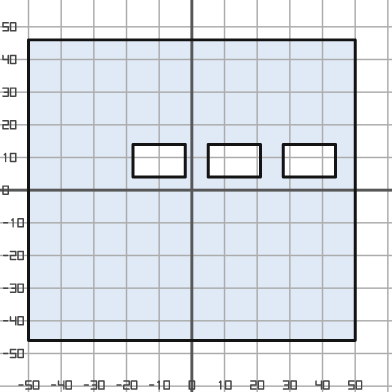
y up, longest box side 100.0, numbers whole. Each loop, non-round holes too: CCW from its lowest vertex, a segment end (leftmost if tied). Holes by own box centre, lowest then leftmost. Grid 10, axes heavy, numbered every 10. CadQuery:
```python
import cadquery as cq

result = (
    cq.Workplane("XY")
    .moveTo(-50.0, -46.0)
    .lineTo(50.0, -46.0)
    .lineTo(50.0, 46.0)
    .lineTo(-50.0, 46.0)
    .close()
    .moveTo(-18.0, 4.0)
    .lineTo(-2.0, 4.0)
    .lineTo(-2.0, 14.0)
    .lineTo(-18.0, 14.0)
    .close()
    .moveTo(5.0, 4.0)
    .lineTo(21.0, 4.0)
    .lineTo(21.0, 14.0)
    .lineTo(5.0, 14.0)
    .close()
    .moveTo(28.0, 4.0)
    .lineTo(44.0, 4.0)
    .lineTo(44.0, 14.0)
    .lineTo(28.0, 14.0)
    .close()
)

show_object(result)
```